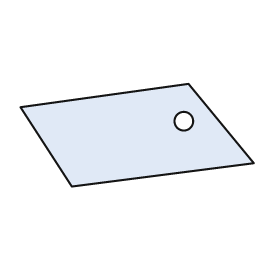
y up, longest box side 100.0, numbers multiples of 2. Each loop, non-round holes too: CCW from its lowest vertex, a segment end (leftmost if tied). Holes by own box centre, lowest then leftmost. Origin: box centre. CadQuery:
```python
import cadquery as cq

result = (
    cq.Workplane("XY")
    .moveTo(-28.0, -22.0)
    .lineTo(50.0, -12.0)
    .lineTo(22.0, 22.0)
    .lineTo(-50.0, 12.0)
    .close()
    .moveTo(20.0, 6.0)
    .circle(4.0)
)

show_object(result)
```